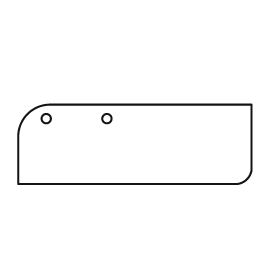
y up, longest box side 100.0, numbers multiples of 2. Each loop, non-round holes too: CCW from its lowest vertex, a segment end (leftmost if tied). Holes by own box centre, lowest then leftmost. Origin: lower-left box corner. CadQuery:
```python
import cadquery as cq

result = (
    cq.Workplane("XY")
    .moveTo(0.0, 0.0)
    .lineTo(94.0, 0.0)
    .threePointArc((98.0, 2.0), (100.0, 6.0))
    .lineTo(100.0, 34.0)
    .lineTo(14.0, 34.0)
    .threePointArc((4.0, 30.0), (0.0, 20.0))
    .close()
    .moveTo(12.0, 28.0)
    .circle(2.0)
    .moveTo(38.0, 28.0)
    .circle(2.0)
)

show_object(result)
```